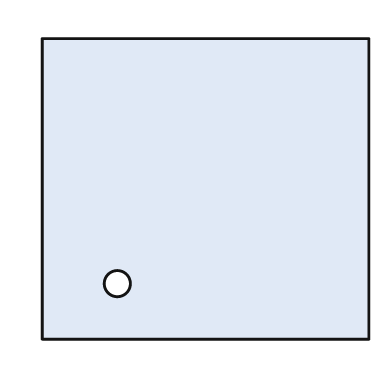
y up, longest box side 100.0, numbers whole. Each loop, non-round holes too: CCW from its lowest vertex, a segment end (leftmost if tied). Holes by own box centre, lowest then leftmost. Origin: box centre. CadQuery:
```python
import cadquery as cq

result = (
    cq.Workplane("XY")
    .moveTo(-50.0, -46.0)
    .lineTo(50.0, -46.0)
    .lineTo(50.0, 46.0)
    .lineTo(-50.0, 46.0)
    .close()
    .moveTo(-27.0, -29.0)
    .circle(4.0)
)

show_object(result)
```